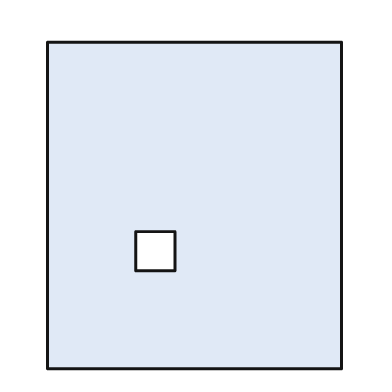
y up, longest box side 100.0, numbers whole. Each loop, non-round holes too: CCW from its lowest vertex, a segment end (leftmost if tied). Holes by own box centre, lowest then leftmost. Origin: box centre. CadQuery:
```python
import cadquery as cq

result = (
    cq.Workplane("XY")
    .moveTo(-45.0, -50.0)
    .lineTo(45.0, -50.0)
    .lineTo(45.0, 50.0)
    .lineTo(-45.0, 50.0)
    .close()
    .moveTo(-18.0, -20.0)
    .lineTo(-6.0, -20.0)
    .lineTo(-6.0, -8.0)
    .lineTo(-18.0, -8.0)
    .close()
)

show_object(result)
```